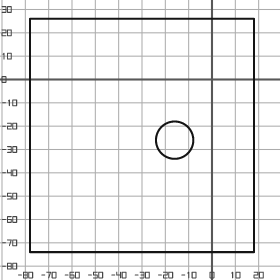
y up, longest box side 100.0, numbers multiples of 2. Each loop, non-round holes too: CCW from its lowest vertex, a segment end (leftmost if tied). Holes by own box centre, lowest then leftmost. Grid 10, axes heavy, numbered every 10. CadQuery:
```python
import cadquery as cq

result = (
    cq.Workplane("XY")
    .moveTo(-78.0, -74.0)
    .lineTo(18.0, -74.0)
    .lineTo(18.0, 26.0)
    .lineTo(-78.0, 26.0)
    .close()
    .moveTo(-16.0, -26.0)
    .circle(8.0)
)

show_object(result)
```